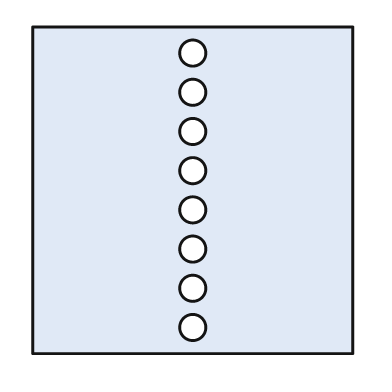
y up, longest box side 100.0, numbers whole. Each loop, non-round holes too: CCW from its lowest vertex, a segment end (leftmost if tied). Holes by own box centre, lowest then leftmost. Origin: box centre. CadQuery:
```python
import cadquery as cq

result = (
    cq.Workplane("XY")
    .moveTo(-49.0, -50.0)
    .lineTo(49.0, -50.0)
    .lineTo(49.0, 50.0)
    .lineTo(-49.0, 50.0)
    .close()
    .moveTo(0.0, -42.0)
    .circle(4.0)
    .moveTo(0.0, -30.0)
    .circle(4.0)
    .moveTo(0.0, -18.0)
    .circle(4.0)
    .moveTo(0.0, -6.0)
    .circle(4.0)
    .moveTo(0.0, 6.0)
    .circle(4.0)
    .moveTo(0.0, 18.0)
    .circle(4.0)
    .moveTo(0.0, 30.0)
    .circle(4.0)
    .moveTo(0.0, 42.0)
    .circle(4.0)
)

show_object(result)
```